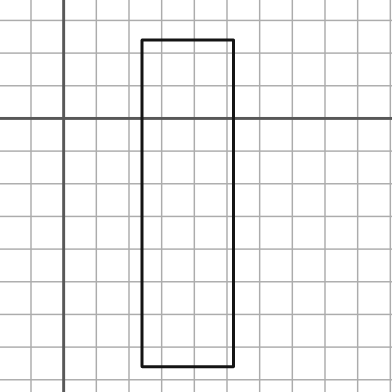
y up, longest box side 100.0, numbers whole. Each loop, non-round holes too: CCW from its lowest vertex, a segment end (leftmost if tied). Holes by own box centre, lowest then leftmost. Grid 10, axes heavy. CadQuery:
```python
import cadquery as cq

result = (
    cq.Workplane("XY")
    .moveTo(24.0, -76.0)
    .lineTo(52.0, -76.0)
    .lineTo(52.0, 24.0)
    .lineTo(24.0, 24.0)
    .close()
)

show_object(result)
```